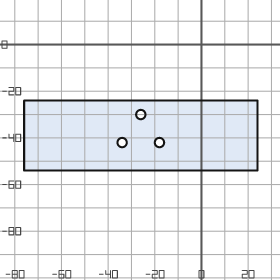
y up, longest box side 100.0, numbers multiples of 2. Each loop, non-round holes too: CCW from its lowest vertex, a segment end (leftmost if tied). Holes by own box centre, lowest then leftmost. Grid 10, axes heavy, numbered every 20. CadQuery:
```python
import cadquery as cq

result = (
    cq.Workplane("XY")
    .moveTo(-76.0, -54.0)
    .lineTo(24.0, -54.0)
    .lineTo(24.0, -24.0)
    .lineTo(-76.0, -24.0)
    .close()
    .moveTo(-34.0, -42.0)
    .circle(2.0)
    .moveTo(-18.0, -42.0)
    .circle(2.0)
    .moveTo(-26.0, -30.0)
    .circle(2.0)
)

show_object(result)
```